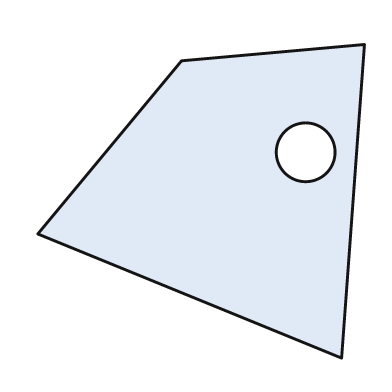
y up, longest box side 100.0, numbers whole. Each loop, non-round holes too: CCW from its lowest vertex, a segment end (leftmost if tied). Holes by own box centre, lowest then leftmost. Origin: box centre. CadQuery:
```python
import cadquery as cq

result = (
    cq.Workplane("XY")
    .moveTo(43.0, -48.0)
    .lineTo(50.0, 48.0)
    .lineTo(-6.0, 43.0)
    .lineTo(-50.0, -10.0)
    .close()
    .moveTo(32.0, 15.0)
    .circle(9.0)
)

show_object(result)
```